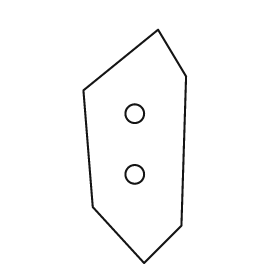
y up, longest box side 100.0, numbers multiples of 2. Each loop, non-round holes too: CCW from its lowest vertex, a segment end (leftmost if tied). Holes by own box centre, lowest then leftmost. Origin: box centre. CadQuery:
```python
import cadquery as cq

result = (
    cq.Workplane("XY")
    .moveTo(4.0, -50.0)
    .lineTo(20.0, -34.0)
    .lineTo(22.0, 30.0)
    .lineTo(10.0, 50.0)
    .lineTo(-22.0, 24.0)
    .lineTo(-18.0, -26.0)
    .close()
    .moveTo(0.0, -12.0)
    .circle(4.0)
    .moveTo(0.0, 14.0)
    .circle(4.0)
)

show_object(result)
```